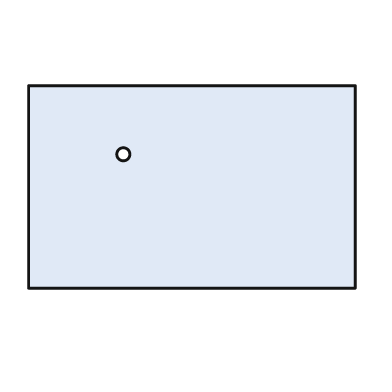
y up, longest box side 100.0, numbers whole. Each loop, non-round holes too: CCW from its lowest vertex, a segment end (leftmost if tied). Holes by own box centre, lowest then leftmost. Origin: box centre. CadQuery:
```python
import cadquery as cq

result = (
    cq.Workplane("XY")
    .moveTo(-50.0, -31.0)
    .lineTo(50.0, -31.0)
    .lineTo(50.0, 31.0)
    .lineTo(-50.0, 31.0)
    .close()
    .moveTo(-21.0, 10.0)
    .circle(2.0)
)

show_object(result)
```